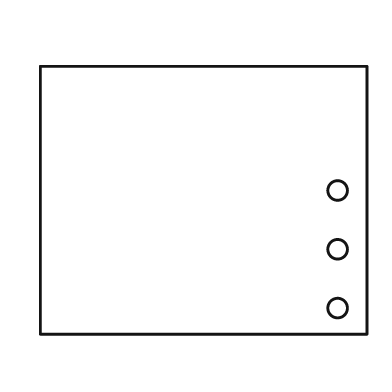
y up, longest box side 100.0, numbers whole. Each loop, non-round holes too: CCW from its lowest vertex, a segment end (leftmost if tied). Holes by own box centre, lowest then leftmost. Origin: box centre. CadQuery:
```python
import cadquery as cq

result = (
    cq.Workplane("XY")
    .moveTo(-50.0, -41.0)
    .lineTo(50.0, -41.0)
    .lineTo(50.0, 41.0)
    .lineTo(-50.0, 41.0)
    .close()
    .moveTo(41.0, -33.0)
    .circle(3.0)
    .moveTo(41.0, -15.0)
    .circle(3.0)
    .moveTo(41.0, 3.0)
    .circle(3.0)
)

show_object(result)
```